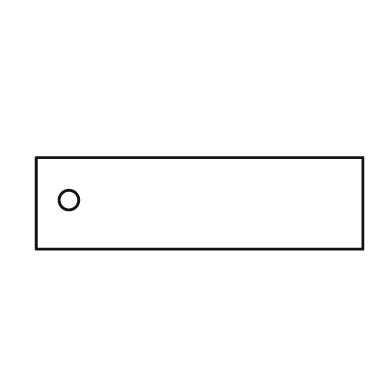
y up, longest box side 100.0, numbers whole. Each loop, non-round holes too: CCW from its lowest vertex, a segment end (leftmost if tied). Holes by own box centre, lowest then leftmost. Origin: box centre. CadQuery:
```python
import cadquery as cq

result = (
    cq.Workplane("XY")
    .moveTo(-50.0, -14.0)
    .lineTo(50.0, -14.0)
    .lineTo(50.0, 14.0)
    .lineTo(-50.0, 14.0)
    .close()
    .moveTo(-40.0, 1.0)
    .circle(3.0)
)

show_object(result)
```